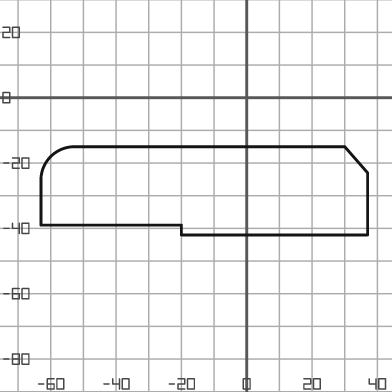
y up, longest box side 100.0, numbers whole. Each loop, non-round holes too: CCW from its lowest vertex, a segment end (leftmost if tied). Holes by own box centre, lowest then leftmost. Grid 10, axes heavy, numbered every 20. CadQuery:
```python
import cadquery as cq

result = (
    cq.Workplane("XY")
    .moveTo(-20.0, -42.0)
    .lineTo(37.0, -42.0)
    .lineTo(37.0, -23.0)
    .lineTo(30.0, -15.0)
    .lineTo(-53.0, -15.0)
    .threePointArc((-60.0, -18.0), (-63.0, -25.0))
    .lineTo(-63.0, -39.0)
    .lineTo(-20.0, -39.0)
    .close()
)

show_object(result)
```